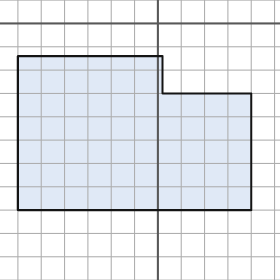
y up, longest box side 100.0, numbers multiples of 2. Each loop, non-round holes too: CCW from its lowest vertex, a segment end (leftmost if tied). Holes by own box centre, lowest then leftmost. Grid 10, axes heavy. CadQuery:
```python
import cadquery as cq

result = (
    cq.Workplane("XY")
    .moveTo(-60.0, -80.0)
    .lineTo(40.0, -80.0)
    .lineTo(40.0, -30.0)
    .lineTo(2.0, -30.0)
    .lineTo(2.0, -14.0)
    .lineTo(-60.0, -14.0)
    .close()
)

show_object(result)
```